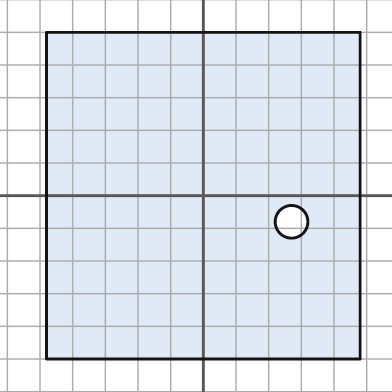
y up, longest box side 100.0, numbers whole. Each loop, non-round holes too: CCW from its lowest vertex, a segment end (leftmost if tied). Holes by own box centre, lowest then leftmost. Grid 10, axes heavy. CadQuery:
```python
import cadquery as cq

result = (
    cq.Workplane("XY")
    .moveTo(-48.0, -50.0)
    .lineTo(48.0, -50.0)
    .lineTo(48.0, 50.0)
    .lineTo(-48.0, 50.0)
    .close()
    .moveTo(27.0, -8.0)
    .circle(5.0)
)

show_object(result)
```